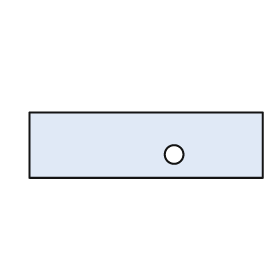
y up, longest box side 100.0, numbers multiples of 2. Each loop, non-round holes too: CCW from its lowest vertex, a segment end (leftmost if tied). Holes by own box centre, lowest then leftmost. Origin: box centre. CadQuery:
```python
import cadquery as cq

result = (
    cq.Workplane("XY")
    .moveTo(-50.0, -14.0)
    .lineTo(50.0, -14.0)
    .lineTo(50.0, 14.0)
    .lineTo(-50.0, 14.0)
    .close()
    .moveTo(12.0, -4.0)
    .circle(4.0)
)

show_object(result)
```